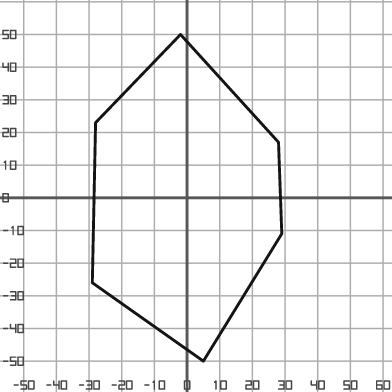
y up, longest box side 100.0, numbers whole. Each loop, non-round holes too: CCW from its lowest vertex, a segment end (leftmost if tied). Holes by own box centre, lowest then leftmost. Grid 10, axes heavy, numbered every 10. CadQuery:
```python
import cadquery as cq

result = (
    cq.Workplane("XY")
    .moveTo(5.0, -50.0)
    .lineTo(29.0, -11.0)
    .lineTo(28.0, 17.0)
    .lineTo(-2.0, 50.0)
    .lineTo(-28.0, 23.0)
    .lineTo(-29.0, -26.0)
    .close()
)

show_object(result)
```